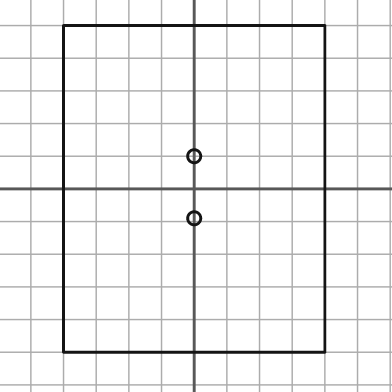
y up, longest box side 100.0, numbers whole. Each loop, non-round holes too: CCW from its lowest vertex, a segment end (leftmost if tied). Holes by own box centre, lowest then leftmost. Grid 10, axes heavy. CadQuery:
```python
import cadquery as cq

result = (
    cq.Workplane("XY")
    .moveTo(-40.0, -50.0)
    .lineTo(40.0, -50.0)
    .lineTo(40.0, 50.0)
    .lineTo(-40.0, 50.0)
    .close()
    .moveTo(0.0, -9.0)
    .circle(2.0)
    .moveTo(0.0, 10.0)
    .circle(2.0)
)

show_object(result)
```